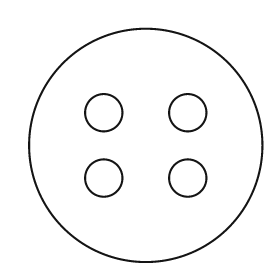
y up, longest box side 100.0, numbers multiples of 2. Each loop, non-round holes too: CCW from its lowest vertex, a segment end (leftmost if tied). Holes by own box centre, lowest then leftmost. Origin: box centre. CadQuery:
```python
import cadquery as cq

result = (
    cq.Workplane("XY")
    .moveTo(0.0, 0.0)
    .circle(50.0)
    .moveTo(-18.0, -14.0)
    .circle(8.0)
    .moveTo(18.0, -14.0)
    .circle(8.0)
    .moveTo(-18.0, 14.0)
    .circle(8.0)
    .moveTo(18.0, 14.0)
    .circle(8.0)
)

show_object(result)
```